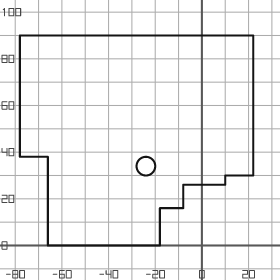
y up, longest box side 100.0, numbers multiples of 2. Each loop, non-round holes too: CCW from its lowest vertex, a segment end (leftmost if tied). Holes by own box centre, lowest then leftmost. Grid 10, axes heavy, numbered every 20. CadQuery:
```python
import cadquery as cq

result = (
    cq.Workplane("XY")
    .moveTo(-66.0, 0.0)
    .lineTo(-18.0, 0.0)
    .lineTo(-18.0, 16.0)
    .lineTo(-8.0, 16.0)
    .lineTo(-8.0, 26.0)
    .lineTo(10.0, 26.0)
    .lineTo(10.0, 30.0)
    .lineTo(22.0, 30.0)
    .lineTo(22.0, 90.0)
    .lineTo(-78.0, 90.0)
    .lineTo(-78.0, 38.0)
    .lineTo(-66.0, 38.0)
    .close()
    .moveTo(-24.0, 34.0)
    .circle(4.0)
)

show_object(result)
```